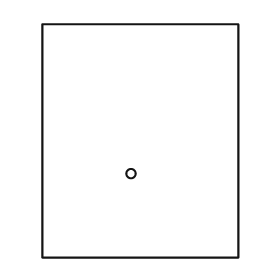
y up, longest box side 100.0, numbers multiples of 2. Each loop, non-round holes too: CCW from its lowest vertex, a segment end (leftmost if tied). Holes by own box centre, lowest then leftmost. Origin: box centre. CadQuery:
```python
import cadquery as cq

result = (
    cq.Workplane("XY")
    .moveTo(-42.0, -50.0)
    .lineTo(42.0, -50.0)
    .lineTo(42.0, 50.0)
    .lineTo(-42.0, 50.0)
    .close()
    .moveTo(-4.0, -14.0)
    .circle(2.0)
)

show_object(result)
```